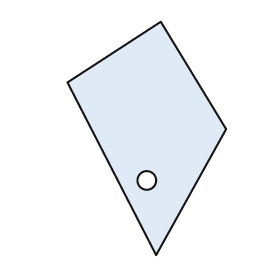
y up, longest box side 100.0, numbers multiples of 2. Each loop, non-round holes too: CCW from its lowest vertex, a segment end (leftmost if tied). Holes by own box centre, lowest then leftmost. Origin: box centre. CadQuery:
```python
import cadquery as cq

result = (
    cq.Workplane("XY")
    .moveTo(4.0, -50.0)
    .lineTo(34.0, 4.0)
    .lineTo(6.0, 50.0)
    .lineTo(-34.0, 24.0)
    .close()
    .moveTo(0.0, -18.0)
    .circle(4.0)
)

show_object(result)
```